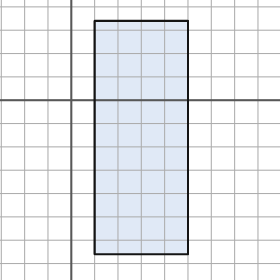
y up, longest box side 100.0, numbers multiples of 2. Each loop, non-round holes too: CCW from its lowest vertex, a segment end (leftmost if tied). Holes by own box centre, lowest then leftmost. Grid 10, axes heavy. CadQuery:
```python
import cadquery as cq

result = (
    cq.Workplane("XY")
    .moveTo(10.0, -66.0)
    .lineTo(50.0, -66.0)
    .lineTo(50.0, 34.0)
    .lineTo(10.0, 34.0)
    .close()
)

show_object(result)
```